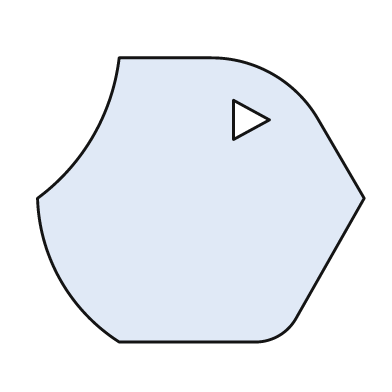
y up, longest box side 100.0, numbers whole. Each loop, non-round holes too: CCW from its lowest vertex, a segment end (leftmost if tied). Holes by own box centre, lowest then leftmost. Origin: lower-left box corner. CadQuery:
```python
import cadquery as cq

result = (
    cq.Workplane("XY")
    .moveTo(25.0, 0.0)
    .lineTo(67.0, 0.0)
    .threePointArc((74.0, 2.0), (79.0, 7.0))
    .lineTo(100.0, 44.0)
    .lineTo(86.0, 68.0)
    .threePointArc((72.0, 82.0), (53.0, 87.0))
    .lineTo(25.0, 87.0)
    .threePointArc((17.0, 63.0), (0.0, 44.0))
    .threePointArc((7.0, 19.0), (25.0, 0.0))
    .close()
    .moveTo(60.0, 62.0)
    .lineTo(71.0, 68.0)
    .lineTo(60.0, 74.0)
    .close()
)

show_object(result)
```